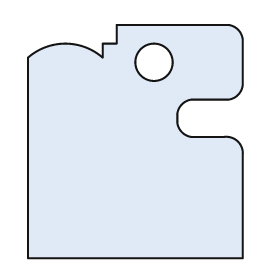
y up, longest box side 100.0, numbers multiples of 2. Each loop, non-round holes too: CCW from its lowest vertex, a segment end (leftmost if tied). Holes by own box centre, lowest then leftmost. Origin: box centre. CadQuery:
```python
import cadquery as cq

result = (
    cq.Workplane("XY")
    .moveTo(-46.0, -50.0)
    .lineTo(46.0, -50.0)
    .lineTo(46.0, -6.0)
    .threePointArc((44.0, 0.0), (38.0, 2.0))
    .lineTo(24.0, 2.0)
    .threePointArc((20.0, 4.0), (18.0, 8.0))
    .lineTo(18.0, 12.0)
    .threePointArc((20.0, 16.0), (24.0, 18.0))
    .lineTo(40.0, 18.0)
    .threePointArc((44.0, 20.0), (46.0, 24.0))
    .lineTo(46.0, 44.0)
    .threePointArc((44.0, 48.0), (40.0, 50.0))
    .lineTo(-8.0, 50.0)
    .lineTo(-8.0, 42.0)
    .lineTo(-14.0, 42.0)
    .lineTo(-14.0, 36.0)
    .threePointArc((-30.0, 42.0), (-46.0, 36.0))
    .close()
    .moveTo(8.0, 34.0)
    .circle(8.0)
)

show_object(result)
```